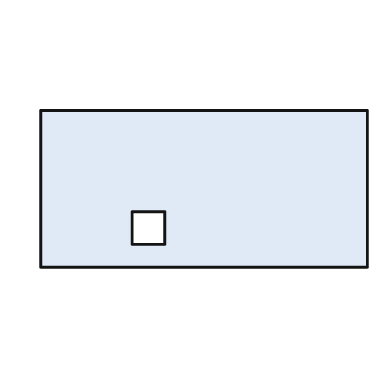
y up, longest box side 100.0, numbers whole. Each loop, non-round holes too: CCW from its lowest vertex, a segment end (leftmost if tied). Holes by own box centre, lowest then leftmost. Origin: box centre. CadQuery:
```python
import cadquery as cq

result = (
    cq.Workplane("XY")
    .moveTo(-50.0, -24.0)
    .lineTo(50.0, -24.0)
    .lineTo(50.0, 24.0)
    .lineTo(-50.0, 24.0)
    .close()
    .moveTo(-22.0, -17.0)
    .lineTo(-12.0, -17.0)
    .lineTo(-12.0, -7.0)
    .lineTo(-22.0, -7.0)
    .close()
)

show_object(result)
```